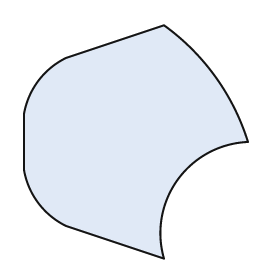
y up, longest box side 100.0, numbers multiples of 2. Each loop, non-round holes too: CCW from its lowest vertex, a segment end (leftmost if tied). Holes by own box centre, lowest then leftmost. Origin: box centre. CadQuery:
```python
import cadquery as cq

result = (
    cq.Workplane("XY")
    .moveTo(12.0, -50.0)
    .threePointArc((18.0, -16.0), (48.0, 0.0))
    .threePointArc((34.0, 28.0), (12.0, 50.0))
    .lineTo(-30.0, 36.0)
    .threePointArc((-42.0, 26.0), (-48.0, 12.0))
    .lineTo(-48.0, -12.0)
    .threePointArc((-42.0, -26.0), (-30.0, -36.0))
    .close()
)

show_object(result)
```